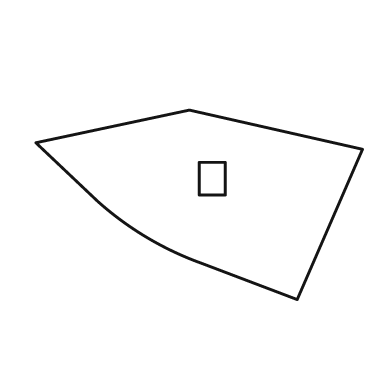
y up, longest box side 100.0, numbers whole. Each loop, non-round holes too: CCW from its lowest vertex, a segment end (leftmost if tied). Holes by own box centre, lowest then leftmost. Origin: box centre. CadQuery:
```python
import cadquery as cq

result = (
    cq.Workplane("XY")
    .moveTo(30.0, -29.0)
    .lineTo(50.0, 17.0)
    .lineTo(-3.0, 29.0)
    .lineTo(-50.0, 19.0)
    .lineTo(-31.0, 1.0)
    .threePointArc((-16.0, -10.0), (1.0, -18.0))
    .close()
    .moveTo(0.0, 3.0)
    .lineTo(8.0, 3.0)
    .lineTo(8.0, 13.0)
    .lineTo(0.0, 13.0)
    .close()
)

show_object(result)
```